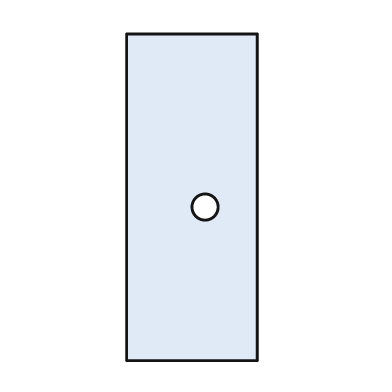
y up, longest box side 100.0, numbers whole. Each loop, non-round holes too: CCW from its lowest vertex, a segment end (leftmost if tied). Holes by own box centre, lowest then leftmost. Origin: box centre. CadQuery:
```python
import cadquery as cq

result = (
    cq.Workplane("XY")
    .moveTo(-20.0, -50.0)
    .lineTo(20.0, -50.0)
    .lineTo(20.0, 50.0)
    .lineTo(-20.0, 50.0)
    .close()
    .moveTo(4.0, -3.0)
    .circle(4.0)
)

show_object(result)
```